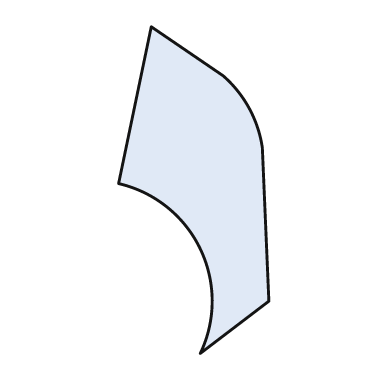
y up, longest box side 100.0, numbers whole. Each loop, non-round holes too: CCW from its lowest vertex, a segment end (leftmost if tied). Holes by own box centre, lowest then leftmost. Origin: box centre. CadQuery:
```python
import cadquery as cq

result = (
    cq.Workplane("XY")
    .moveTo(2.0, -50.0)
    .lineTo(23.0, -34.0)
    .lineTo(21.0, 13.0)
    .threePointArc((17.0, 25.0), (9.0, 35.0))
    .lineTo(-13.0, 50.0)
    .lineTo(-23.0, 2.0)
    .threePointArc((2.0, -18.0), (2.0, -50.0))
    .close()
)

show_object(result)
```